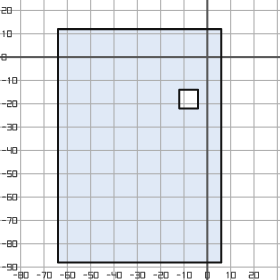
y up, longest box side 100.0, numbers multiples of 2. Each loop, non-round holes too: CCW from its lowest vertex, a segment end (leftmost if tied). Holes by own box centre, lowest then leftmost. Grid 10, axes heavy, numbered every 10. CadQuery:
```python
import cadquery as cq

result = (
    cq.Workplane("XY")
    .moveTo(-64.0, -88.0)
    .lineTo(6.0, -88.0)
    .lineTo(6.0, 12.0)
    .lineTo(-64.0, 12.0)
    .close()
    .moveTo(-12.0, -22.0)
    .lineTo(-4.0, -22.0)
    .lineTo(-4.0, -14.0)
    .lineTo(-12.0, -14.0)
    .close()
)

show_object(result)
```